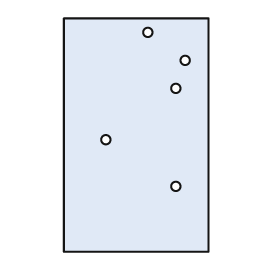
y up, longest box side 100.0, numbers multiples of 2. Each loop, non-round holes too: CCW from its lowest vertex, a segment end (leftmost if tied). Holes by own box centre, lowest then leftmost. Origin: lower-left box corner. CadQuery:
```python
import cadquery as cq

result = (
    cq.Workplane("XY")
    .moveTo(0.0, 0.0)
    .lineTo(62.0, 0.0)
    .lineTo(62.0, 100.0)
    .lineTo(0.0, 100.0)
    .close()
    .moveTo(48.0, 28.0)
    .circle(2.0)
    .moveTo(18.0, 48.0)
    .circle(2.0)
    .moveTo(48.0, 70.0)
    .circle(2.0)
    .moveTo(52.0, 82.0)
    .circle(2.0)
    .moveTo(36.0, 94.0)
    .circle(2.0)
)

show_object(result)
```